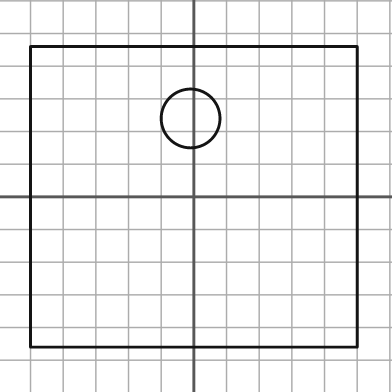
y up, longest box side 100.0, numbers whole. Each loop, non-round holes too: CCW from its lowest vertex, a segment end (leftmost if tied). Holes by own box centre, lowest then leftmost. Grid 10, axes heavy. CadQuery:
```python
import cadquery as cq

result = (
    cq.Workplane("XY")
    .moveTo(-50.0, -46.0)
    .lineTo(50.0, -46.0)
    .lineTo(50.0, 46.0)
    .lineTo(-50.0, 46.0)
    .close()
    .moveTo(-1.0, 24.0)
    .circle(9.0)
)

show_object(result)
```